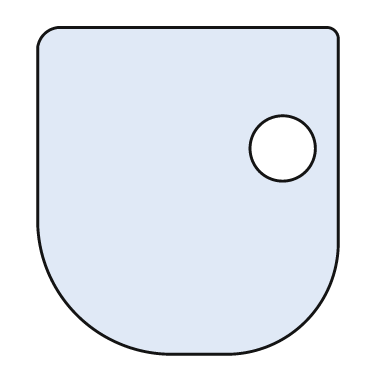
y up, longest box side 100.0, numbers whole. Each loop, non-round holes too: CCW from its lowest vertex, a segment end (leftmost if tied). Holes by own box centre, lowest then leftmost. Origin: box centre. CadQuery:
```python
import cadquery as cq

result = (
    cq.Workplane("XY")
    .moveTo(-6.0, -50.0)
    .lineTo(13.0, -50.0)
    .threePointArc((36.0, -40.0), (46.0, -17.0))
    .lineTo(46.0, 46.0)
    .threePointArc((45.0, 49.0), (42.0, 50.0))
    .lineTo(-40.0, 50.0)
    .threePointArc((-44.0, 48.0), (-46.0, 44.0))
    .lineTo(-46.0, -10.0)
    .threePointArc((-34.0, -38.0), (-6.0, -50.0))
    .close()
    .moveTo(29.0, 13.0)
    .circle(10.0)
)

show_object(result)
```